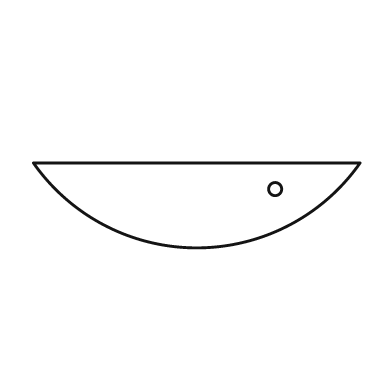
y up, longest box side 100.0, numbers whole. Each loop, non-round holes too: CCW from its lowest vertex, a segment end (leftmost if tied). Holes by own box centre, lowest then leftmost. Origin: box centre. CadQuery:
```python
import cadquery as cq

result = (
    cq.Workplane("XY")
    .moveTo(-50.0, 13.0)
    .threePointArc((0.0, -13.0), (50.0, 13.0))
    .close()
    .moveTo(24.0, 5.0)
    .circle(2.0)
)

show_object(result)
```